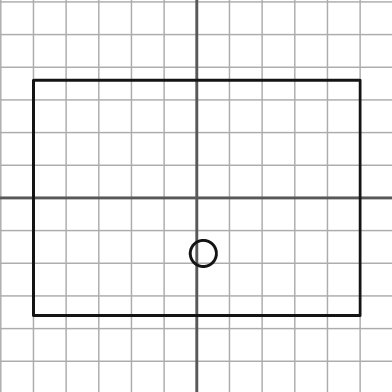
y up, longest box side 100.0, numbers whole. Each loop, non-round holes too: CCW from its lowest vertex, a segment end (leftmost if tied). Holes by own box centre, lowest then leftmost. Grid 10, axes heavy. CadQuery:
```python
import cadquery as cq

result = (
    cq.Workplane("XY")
    .moveTo(-50.0, -36.0)
    .lineTo(50.0, -36.0)
    .lineTo(50.0, 36.0)
    .lineTo(-50.0, 36.0)
    .close()
    .moveTo(2.0, -17.0)
    .circle(4.0)
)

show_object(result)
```